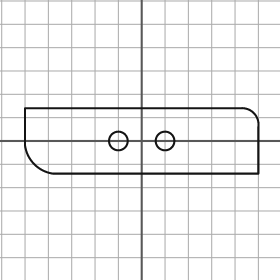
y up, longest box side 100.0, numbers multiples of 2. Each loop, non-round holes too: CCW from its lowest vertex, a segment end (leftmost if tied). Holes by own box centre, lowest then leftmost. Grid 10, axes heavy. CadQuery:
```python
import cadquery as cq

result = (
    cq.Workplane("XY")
    .moveTo(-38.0, -14.0)
    .lineTo(50.0, -14.0)
    .lineTo(50.0, 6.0)
    .threePointArc((48.0, 12.0), (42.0, 14.0))
    .lineTo(-50.0, 14.0)
    .lineTo(-50.0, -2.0)
    .threePointArc((-46.0, -10.0), (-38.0, -14.0))
    .close()
    .moveTo(-10.0, 0.0)
    .circle(4.0)
    .moveTo(10.0, 0.0)
    .circle(4.0)
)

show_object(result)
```